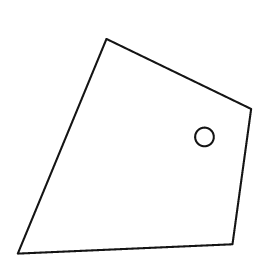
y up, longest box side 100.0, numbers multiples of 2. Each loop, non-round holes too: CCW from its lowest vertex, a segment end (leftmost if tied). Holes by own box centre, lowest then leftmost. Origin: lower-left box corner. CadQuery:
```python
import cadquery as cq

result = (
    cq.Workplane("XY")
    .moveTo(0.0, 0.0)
    .lineTo(92.0, 4.0)
    .lineTo(100.0, 62.0)
    .lineTo(38.0, 92.0)
    .close()
    .moveTo(80.0, 50.0)
    .circle(4.0)
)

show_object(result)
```